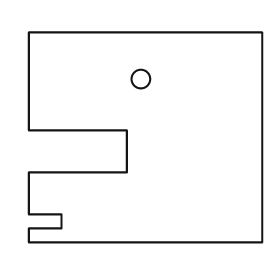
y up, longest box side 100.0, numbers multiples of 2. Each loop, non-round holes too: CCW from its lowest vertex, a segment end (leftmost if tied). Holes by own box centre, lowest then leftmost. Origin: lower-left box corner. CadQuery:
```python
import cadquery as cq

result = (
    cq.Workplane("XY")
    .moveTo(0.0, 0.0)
    .lineTo(100.0, 0.0)
    .lineTo(100.0, 90.0)
    .lineTo(0.0, 90.0)
    .lineTo(0.0, 48.0)
    .lineTo(42.0, 48.0)
    .lineTo(42.0, 30.0)
    .lineTo(0.0, 30.0)
    .lineTo(0.0, 12.0)
    .lineTo(14.0, 12.0)
    .lineTo(14.0, 6.0)
    .lineTo(0.0, 6.0)
    .close()
    .moveTo(48.0, 70.0)
    .circle(4.0)
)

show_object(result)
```